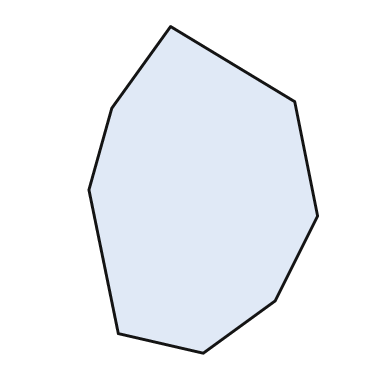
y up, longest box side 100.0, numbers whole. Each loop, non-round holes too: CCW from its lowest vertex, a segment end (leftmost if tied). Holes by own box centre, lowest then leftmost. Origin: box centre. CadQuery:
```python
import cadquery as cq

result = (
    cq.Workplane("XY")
    .moveTo(0.0, -50.0)
    .lineTo(22.0, -34.0)
    .lineTo(35.0, -8.0)
    .lineTo(28.0, 27.0)
    .lineTo(-10.0, 50.0)
    .lineTo(-28.0, 25.0)
    .lineTo(-35.0, 0.0)
    .lineTo(-26.0, -44.0)
    .close()
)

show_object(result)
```